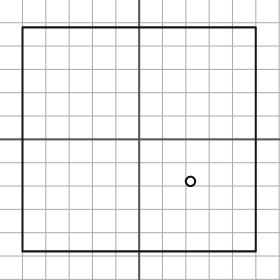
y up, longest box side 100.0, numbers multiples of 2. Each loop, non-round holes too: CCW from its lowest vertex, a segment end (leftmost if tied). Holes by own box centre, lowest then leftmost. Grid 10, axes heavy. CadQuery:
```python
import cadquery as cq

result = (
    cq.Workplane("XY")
    .moveTo(-50.0, -48.0)
    .lineTo(50.0, -48.0)
    .lineTo(50.0, 48.0)
    .lineTo(-50.0, 48.0)
    .close()
    .moveTo(22.0, -18.0)
    .circle(2.0)
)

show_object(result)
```